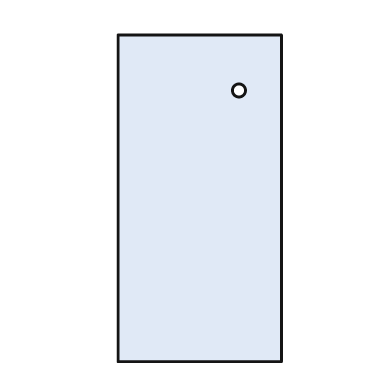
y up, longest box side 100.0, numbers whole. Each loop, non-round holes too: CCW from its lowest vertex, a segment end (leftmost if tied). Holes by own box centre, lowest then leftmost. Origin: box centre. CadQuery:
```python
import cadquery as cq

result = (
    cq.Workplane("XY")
    .moveTo(-25.0, -50.0)
    .lineTo(25.0, -50.0)
    .lineTo(25.0, 50.0)
    .lineTo(-25.0, 50.0)
    .close()
    .moveTo(12.0, 33.0)
    .circle(2.0)
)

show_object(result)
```